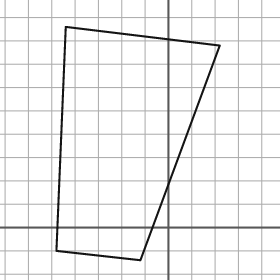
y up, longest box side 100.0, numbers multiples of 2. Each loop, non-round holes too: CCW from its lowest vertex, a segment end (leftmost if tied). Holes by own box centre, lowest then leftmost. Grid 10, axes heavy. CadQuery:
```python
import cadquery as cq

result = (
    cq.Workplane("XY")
    .moveTo(-12.0, -14.0)
    .lineTo(22.0, 78.0)
    .lineTo(-44.0, 86.0)
    .lineTo(-48.0, -10.0)
    .close()
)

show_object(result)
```